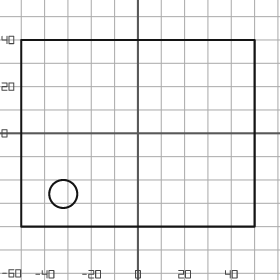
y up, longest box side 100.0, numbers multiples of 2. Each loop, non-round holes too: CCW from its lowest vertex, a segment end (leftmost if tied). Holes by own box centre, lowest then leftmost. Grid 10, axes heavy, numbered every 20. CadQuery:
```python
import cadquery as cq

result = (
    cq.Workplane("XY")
    .moveTo(-50.0, -40.0)
    .lineTo(50.0, -40.0)
    .lineTo(50.0, 40.0)
    .lineTo(-50.0, 40.0)
    .close()
    .moveTo(-32.0, -26.0)
    .circle(6.0)
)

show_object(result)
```